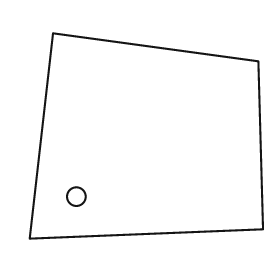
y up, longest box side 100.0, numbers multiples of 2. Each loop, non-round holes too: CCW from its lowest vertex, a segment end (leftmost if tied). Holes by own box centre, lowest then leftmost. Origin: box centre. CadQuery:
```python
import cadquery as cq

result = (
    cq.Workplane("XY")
    .moveTo(-50.0, -44.0)
    .lineTo(50.0, -40.0)
    .lineTo(48.0, 32.0)
    .lineTo(-40.0, 44.0)
    .close()
    .moveTo(-30.0, -26.0)
    .circle(4.0)
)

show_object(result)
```